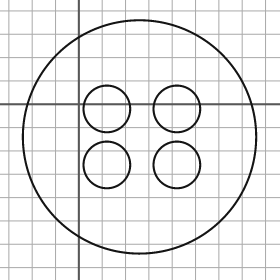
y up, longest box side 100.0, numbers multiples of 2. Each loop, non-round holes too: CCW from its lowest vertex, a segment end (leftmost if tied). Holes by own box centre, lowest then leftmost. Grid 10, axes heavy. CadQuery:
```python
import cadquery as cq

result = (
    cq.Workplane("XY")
    .moveTo(26.0, -14.0)
    .circle(50.0)
    .moveTo(12.0, -26.0)
    .circle(10.0)
    .moveTo(42.0, -26.0)
    .circle(10.0)
    .moveTo(12.0, -2.0)
    .circle(10.0)
    .moveTo(42.0, -2.0)
    .circle(10.0)
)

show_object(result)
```